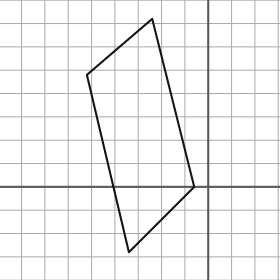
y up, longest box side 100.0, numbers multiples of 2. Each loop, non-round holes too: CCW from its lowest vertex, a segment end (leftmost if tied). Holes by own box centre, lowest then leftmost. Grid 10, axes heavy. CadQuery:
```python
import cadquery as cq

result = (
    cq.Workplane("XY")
    .moveTo(-34.0, -28.0)
    .lineTo(-6.0, 0.0)
    .lineTo(-24.0, 72.0)
    .lineTo(-52.0, 48.0)
    .close()
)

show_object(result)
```